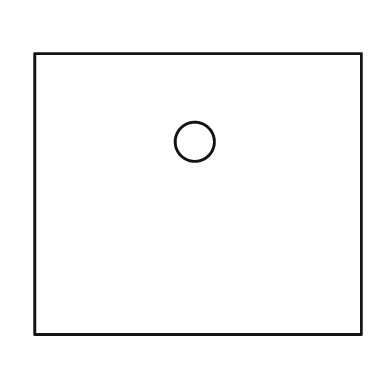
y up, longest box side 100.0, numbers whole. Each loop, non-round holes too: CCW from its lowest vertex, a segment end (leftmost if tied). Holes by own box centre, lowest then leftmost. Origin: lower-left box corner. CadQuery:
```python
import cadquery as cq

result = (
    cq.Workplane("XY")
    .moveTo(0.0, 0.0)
    .lineTo(100.0, 0.0)
    .lineTo(100.0, 86.0)
    .lineTo(0.0, 86.0)
    .close()
    .moveTo(49.0, 59.0)
    .circle(6.0)
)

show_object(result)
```